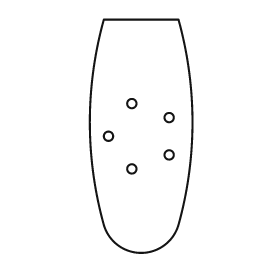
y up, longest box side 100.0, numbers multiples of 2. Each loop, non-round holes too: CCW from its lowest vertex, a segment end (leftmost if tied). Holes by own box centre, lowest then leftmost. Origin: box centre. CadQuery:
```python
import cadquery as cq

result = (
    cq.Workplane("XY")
    .moveTo(-16.0, -38.0)
    .threePointArc((0.0, -50.0), (16.0, -38.0))
    .threePointArc((22.0, 6.0), (16.0, 50.0))
    .lineTo(-16.0, 50.0)
    .threePointArc((-22.0, 6.0), (-16.0, -38.0))
    .close()
    .moveTo(-4.0, -14.0)
    .circle(2.0)
    .moveTo(12.0, -8.0)
    .circle(2.0)
    .moveTo(-14.0, 0.0)
    .circle(2.0)
    .moveTo(12.0, 8.0)
    .circle(2.0)
    .moveTo(-4.0, 14.0)
    .circle(2.0)
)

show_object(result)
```